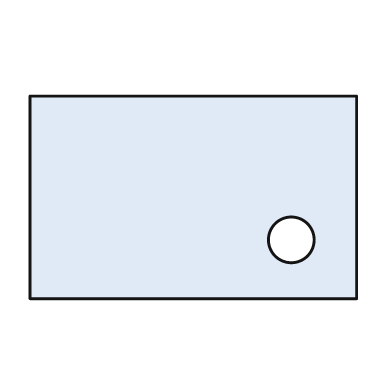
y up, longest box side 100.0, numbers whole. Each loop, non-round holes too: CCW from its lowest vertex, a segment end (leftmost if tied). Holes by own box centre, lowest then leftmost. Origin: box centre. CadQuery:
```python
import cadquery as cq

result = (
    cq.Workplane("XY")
    .moveTo(-50.0, -31.0)
    .lineTo(50.0, -31.0)
    .lineTo(50.0, 31.0)
    .lineTo(-50.0, 31.0)
    .close()
    .moveTo(30.0, -13.0)
    .circle(7.0)
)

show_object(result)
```